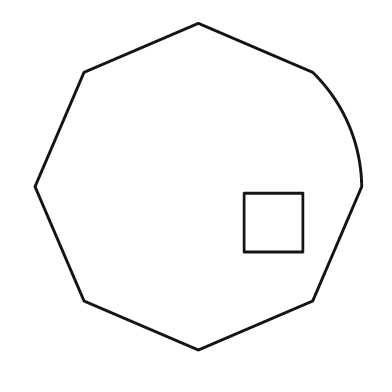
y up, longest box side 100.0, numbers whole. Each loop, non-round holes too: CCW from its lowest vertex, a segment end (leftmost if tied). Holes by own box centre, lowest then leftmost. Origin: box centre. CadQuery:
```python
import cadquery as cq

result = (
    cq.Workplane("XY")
    .moveTo(0.0, -50.0)
    .lineTo(35.0, -35.0)
    .lineTo(50.0, 0.0)
    .threePointArc((46.0, 19.0), (35.0, 35.0))
    .lineTo(0.0, 50.0)
    .lineTo(-35.0, 35.0)
    .lineTo(-50.0, 0.0)
    .lineTo(-35.0, -35.0)
    .close()
    .moveTo(14.0, -20.0)
    .lineTo(32.0, -20.0)
    .lineTo(32.0, -2.0)
    .lineTo(14.0, -2.0)
    .close()
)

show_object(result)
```